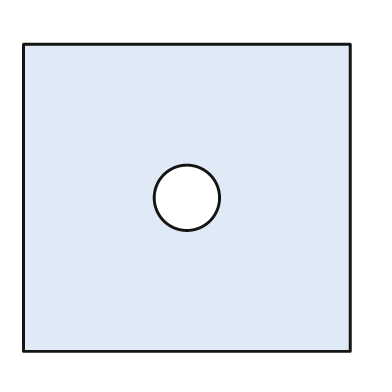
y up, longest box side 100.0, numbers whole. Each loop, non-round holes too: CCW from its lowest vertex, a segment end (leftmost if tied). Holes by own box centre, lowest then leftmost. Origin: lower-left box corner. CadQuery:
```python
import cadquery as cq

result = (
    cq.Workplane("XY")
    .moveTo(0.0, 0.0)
    .lineTo(100.0, 0.0)
    .lineTo(100.0, 94.0)
    .lineTo(0.0, 94.0)
    .close()
    .moveTo(50.0, 47.0)
    .circle(10.0)
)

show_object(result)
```